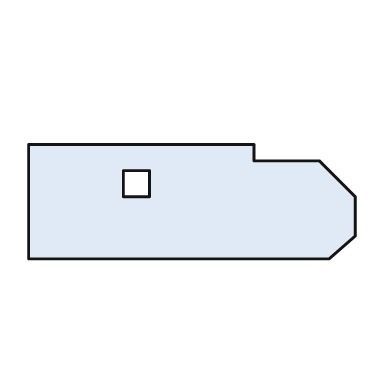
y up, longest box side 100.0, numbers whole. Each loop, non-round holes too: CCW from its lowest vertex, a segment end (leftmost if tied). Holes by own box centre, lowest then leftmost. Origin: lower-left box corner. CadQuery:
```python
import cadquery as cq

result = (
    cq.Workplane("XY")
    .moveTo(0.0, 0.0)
    .lineTo(92.0, 0.0)
    .lineTo(100.0, 7.0)
    .lineTo(100.0, 19.0)
    .lineTo(89.0, 30.0)
    .lineTo(69.0, 30.0)
    .lineTo(69.0, 35.0)
    .lineTo(0.0, 35.0)
    .close()
    .moveTo(29.0, 19.0)
    .lineTo(37.0, 19.0)
    .lineTo(37.0, 27.0)
    .lineTo(29.0, 27.0)
    .close()
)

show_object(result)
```